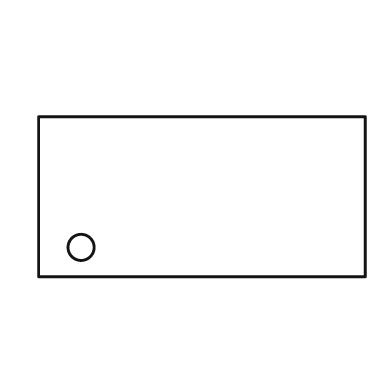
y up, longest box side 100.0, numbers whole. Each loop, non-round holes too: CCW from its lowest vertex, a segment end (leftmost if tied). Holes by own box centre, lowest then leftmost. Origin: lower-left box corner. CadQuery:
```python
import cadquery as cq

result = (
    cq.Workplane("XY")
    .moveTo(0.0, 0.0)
    .lineTo(100.0, 0.0)
    .lineTo(100.0, 49.0)
    .lineTo(0.0, 49.0)
    .close()
    .moveTo(13.0, 9.0)
    .circle(4.0)
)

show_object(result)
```